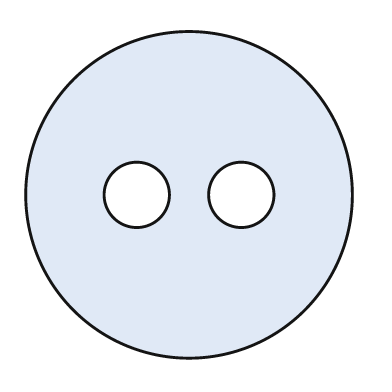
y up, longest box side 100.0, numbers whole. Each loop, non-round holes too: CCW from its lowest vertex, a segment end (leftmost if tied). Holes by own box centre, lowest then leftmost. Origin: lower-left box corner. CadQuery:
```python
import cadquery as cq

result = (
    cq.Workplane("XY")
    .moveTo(50.0, 50.0)
    .circle(50.0)
    .moveTo(34.0, 50.0)
    .circle(10.0)
    .moveTo(66.0, 50.0)
    .circle(10.0)
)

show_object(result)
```